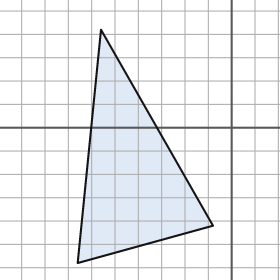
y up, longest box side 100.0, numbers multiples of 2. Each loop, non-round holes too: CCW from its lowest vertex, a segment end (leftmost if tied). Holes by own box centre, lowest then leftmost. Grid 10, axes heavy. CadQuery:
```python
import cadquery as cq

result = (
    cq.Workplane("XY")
    .moveTo(-66.0, -58.0)
    .lineTo(-8.0, -42.0)
    .lineTo(-56.0, 42.0)
    .close()
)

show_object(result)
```